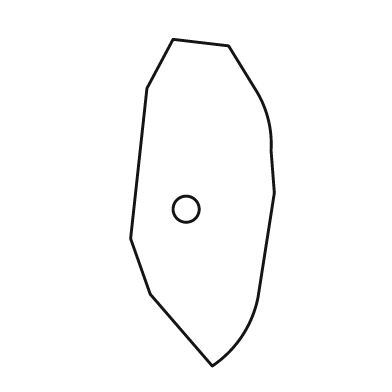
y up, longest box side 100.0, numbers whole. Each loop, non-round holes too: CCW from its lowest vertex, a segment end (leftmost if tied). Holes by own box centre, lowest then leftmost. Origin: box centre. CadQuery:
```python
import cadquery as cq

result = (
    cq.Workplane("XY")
    .moveTo(3.0, -50.0)
    .threePointArc((12.0, -41.0), (17.0, -29.0))
    .lineTo(22.0, 3.0)
    .lineTo(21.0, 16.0)
    .threePointArc((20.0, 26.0), (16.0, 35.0))
    .lineTo(8.0, 48.0)
    .lineTo(-9.0, 50.0)
    .lineTo(-17.0, 35.0)
    .lineTo(-22.0, -11.0)
    .lineTo(-16.0, -28.0)
    .close()
    .moveTo(-5.0, -2.0)
    .circle(4.0)
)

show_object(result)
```